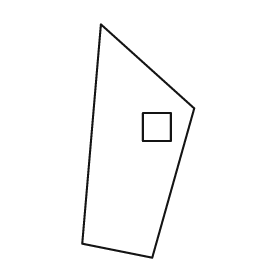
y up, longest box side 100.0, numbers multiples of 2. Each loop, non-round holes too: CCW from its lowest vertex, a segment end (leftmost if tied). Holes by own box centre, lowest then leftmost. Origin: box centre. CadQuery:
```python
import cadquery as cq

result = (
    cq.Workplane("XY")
    .moveTo(6.0, -50.0)
    .lineTo(24.0, 14.0)
    .lineTo(-16.0, 50.0)
    .lineTo(-24.0, -44.0)
    .close()
    .moveTo(2.0, 0.0)
    .lineTo(14.0, 0.0)
    .lineTo(14.0, 12.0)
    .lineTo(2.0, 12.0)
    .close()
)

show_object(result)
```